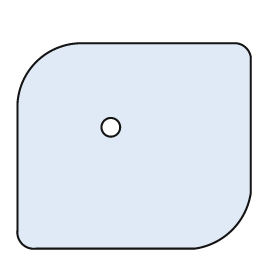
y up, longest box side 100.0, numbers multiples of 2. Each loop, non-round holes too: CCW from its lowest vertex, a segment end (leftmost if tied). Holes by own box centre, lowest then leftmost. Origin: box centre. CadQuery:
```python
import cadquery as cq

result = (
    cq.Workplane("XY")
    .moveTo(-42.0, -44.0)
    .lineTo(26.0, -44.0)
    .threePointArc((42.0, -36.0), (50.0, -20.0))
    .lineTo(50.0, 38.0)
    .threePointArc((48.0, 42.0), (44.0, 44.0))
    .lineTo(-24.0, 44.0)
    .threePointArc((-42.0, 36.0), (-50.0, 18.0))
    .lineTo(-50.0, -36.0)
    .threePointArc((-48.0, -42.0), (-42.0, -44.0))
    .close()
    .moveTo(-10.0, 8.0)
    .circle(4.0)
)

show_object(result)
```